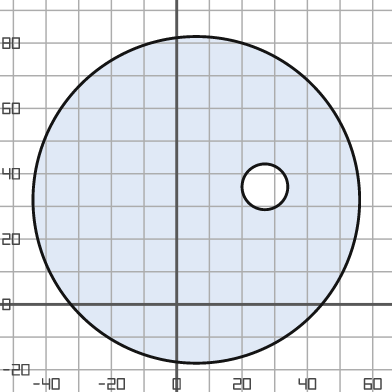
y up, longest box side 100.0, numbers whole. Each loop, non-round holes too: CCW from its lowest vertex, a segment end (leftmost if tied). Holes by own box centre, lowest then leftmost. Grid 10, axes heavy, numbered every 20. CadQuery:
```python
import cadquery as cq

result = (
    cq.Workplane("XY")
    .moveTo(6.0, 32.0)
    .circle(50.0)
    .moveTo(27.0, 36.0)
    .circle(7.0)
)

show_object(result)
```